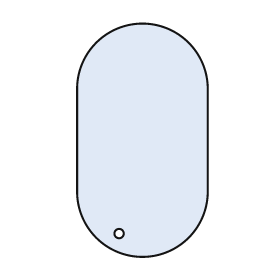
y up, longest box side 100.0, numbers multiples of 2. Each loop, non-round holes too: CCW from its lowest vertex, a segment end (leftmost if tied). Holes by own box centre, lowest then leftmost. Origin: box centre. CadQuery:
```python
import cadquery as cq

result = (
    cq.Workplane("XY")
    .moveTo(-28.0, -22.0)
    .threePointArc((0.0, -50.0), (28.0, -22.0))
    .lineTo(28.0, 22.0)
    .threePointArc((0.0, 50.0), (-28.0, 22.0))
    .close()
    .moveTo(-10.0, -40.0)
    .circle(2.0)
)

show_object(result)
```